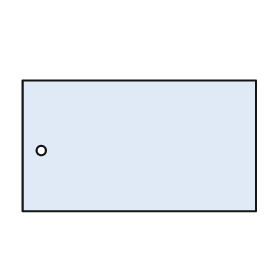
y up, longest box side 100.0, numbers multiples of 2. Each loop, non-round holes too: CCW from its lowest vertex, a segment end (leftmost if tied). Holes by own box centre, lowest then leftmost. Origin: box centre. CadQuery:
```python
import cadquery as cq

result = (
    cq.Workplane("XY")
    .moveTo(-50.0, -28.0)
    .lineTo(50.0, -28.0)
    .lineTo(50.0, 28.0)
    .lineTo(-50.0, 28.0)
    .close()
    .moveTo(-42.0, -2.0)
    .circle(2.0)
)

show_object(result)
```